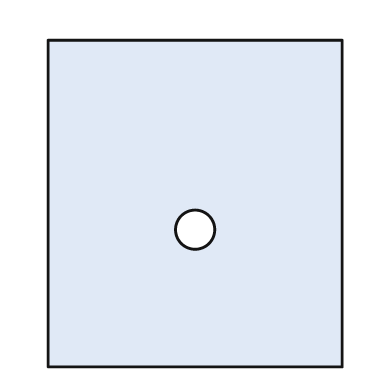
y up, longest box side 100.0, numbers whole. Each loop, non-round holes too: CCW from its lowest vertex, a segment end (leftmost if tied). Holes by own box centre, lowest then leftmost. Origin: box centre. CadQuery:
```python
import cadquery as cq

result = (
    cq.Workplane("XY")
    .moveTo(-45.0, -50.0)
    .lineTo(45.0, -50.0)
    .lineTo(45.0, 50.0)
    .lineTo(-45.0, 50.0)
    .close()
    .moveTo(0.0, -8.0)
    .circle(6.0)
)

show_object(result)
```